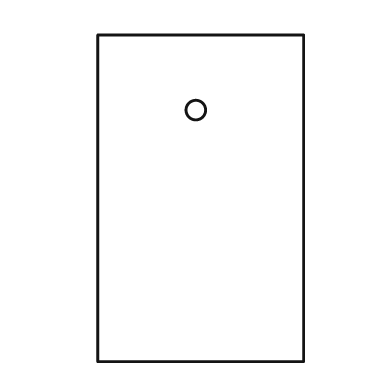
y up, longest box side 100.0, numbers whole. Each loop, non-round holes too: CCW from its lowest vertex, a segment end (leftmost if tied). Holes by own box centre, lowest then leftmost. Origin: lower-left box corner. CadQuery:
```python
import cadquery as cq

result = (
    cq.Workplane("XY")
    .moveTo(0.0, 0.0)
    .lineTo(63.0, 0.0)
    .lineTo(63.0, 100.0)
    .lineTo(0.0, 100.0)
    .close()
    .moveTo(30.0, 77.0)
    .circle(3.0)
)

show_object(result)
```